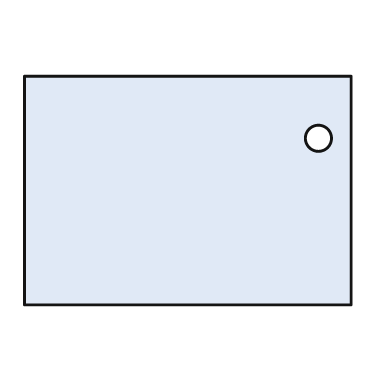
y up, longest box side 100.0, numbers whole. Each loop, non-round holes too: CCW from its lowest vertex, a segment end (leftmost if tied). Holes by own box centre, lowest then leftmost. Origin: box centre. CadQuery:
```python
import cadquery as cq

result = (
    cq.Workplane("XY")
    .moveTo(-50.0, -35.0)
    .lineTo(50.0, -35.0)
    .lineTo(50.0, 35.0)
    .lineTo(-50.0, 35.0)
    .close()
    .moveTo(40.0, 16.0)
    .circle(4.0)
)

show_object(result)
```